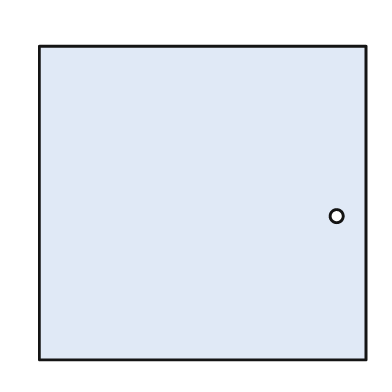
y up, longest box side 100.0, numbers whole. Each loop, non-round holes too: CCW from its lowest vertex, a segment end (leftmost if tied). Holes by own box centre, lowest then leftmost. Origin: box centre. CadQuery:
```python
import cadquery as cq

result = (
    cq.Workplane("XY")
    .moveTo(-50.0, -48.0)
    .lineTo(50.0, -48.0)
    .lineTo(50.0, 48.0)
    .lineTo(-50.0, 48.0)
    .close()
    .moveTo(41.0, -4.0)
    .circle(2.0)
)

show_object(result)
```